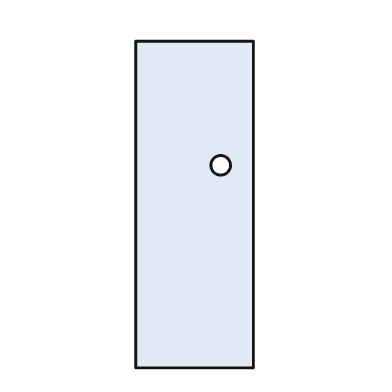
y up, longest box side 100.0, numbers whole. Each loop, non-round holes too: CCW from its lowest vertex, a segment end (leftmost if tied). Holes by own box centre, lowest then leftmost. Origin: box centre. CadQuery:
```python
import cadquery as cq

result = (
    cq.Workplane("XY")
    .moveTo(-18.0, -50.0)
    .lineTo(18.0, -50.0)
    .lineTo(18.0, 50.0)
    .lineTo(-18.0, 50.0)
    .close()
    .moveTo(8.0, 12.0)
    .circle(3.0)
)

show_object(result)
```